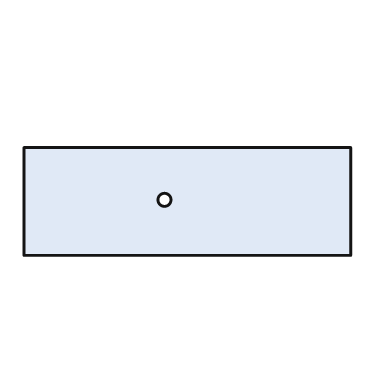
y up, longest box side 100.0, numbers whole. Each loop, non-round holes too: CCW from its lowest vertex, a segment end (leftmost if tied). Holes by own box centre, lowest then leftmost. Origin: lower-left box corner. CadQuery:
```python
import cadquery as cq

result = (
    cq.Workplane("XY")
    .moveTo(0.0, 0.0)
    .lineTo(100.0, 0.0)
    .lineTo(100.0, 33.0)
    .lineTo(0.0, 33.0)
    .close()
    .moveTo(43.0, 17.0)
    .circle(2.0)
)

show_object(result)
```